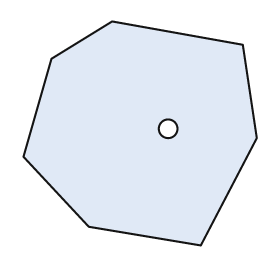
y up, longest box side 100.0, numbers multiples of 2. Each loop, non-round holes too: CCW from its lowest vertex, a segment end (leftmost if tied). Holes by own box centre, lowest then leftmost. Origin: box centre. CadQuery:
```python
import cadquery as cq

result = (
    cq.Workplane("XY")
    .moveTo(26.0, -48.0)
    .lineTo(50.0, -2.0)
    .lineTo(44.0, 38.0)
    .lineTo(-12.0, 48.0)
    .lineTo(-38.0, 32.0)
    .lineTo(-50.0, -10.0)
    .lineTo(-22.0, -40.0)
    .close()
    .moveTo(12.0, 2.0)
    .circle(4.0)
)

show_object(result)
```